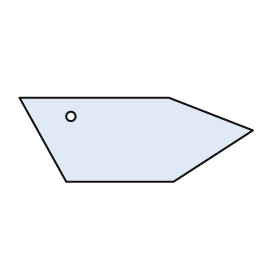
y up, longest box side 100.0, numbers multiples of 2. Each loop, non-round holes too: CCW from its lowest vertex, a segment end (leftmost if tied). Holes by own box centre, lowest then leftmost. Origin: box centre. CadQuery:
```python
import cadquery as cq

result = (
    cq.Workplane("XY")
    .moveTo(-30.0, -18.0)
    .lineTo(16.0, -18.0)
    .lineTo(50.0, 4.0)
    .lineTo(14.0, 18.0)
    .lineTo(-50.0, 18.0)
    .close()
    .moveTo(-28.0, 10.0)
    .circle(2.0)
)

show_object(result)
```